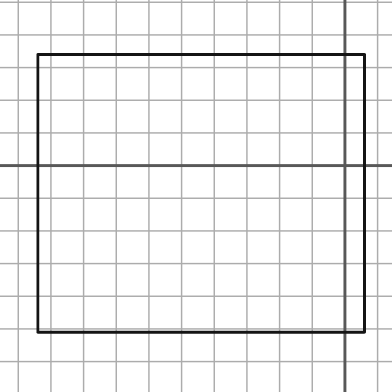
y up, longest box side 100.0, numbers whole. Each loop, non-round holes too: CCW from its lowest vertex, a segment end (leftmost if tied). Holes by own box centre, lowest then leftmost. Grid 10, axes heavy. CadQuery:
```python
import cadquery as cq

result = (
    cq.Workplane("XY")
    .moveTo(-94.0, -51.0)
    .lineTo(6.0, -51.0)
    .lineTo(6.0, 34.0)
    .lineTo(-94.0, 34.0)
    .close()
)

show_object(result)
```